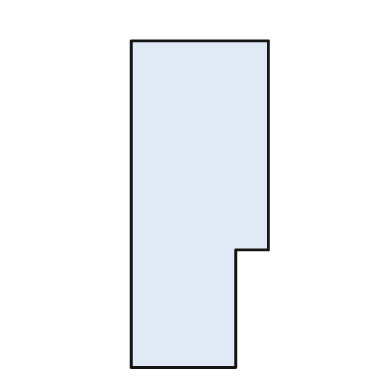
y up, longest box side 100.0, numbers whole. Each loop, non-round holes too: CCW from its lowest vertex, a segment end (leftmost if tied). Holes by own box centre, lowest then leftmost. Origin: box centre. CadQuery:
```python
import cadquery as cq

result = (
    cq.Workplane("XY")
    .moveTo(-21.0, -50.0)
    .lineTo(11.0, -50.0)
    .lineTo(11.0, -14.0)
    .lineTo(21.0, -14.0)
    .lineTo(21.0, 50.0)
    .lineTo(-21.0, 50.0)
    .close()
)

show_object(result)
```